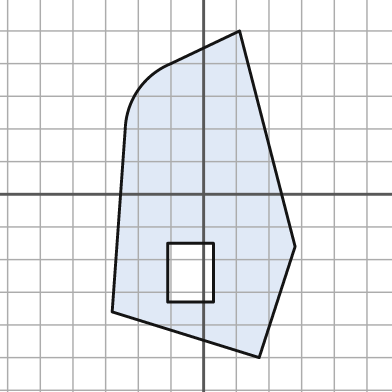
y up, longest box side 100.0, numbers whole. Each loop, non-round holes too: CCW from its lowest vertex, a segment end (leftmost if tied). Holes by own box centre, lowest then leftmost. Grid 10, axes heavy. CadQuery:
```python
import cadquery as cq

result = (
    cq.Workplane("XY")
    .moveTo(17.0, -50.0)
    .lineTo(28.0, -16.0)
    .lineTo(11.0, 50.0)
    .lineTo(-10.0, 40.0)
    .threePointArc((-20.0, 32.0), (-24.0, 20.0))
    .lineTo(-28.0, -36.0)
    .close()
    .moveTo(-11.0, -33.0)
    .lineTo(3.0, -33.0)
    .lineTo(3.0, -15.0)
    .lineTo(-11.0, -15.0)
    .close()
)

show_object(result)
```